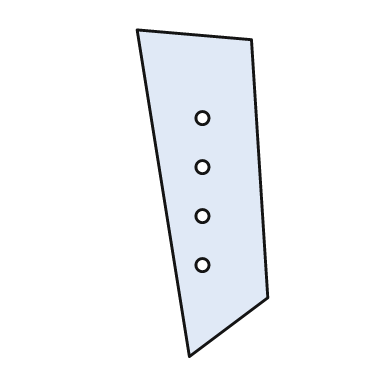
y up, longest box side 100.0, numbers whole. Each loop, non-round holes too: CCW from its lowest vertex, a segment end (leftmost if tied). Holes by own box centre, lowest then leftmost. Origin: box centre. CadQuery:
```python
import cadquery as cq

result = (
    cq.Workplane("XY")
    .moveTo(-4.0, -50.0)
    .lineTo(20.0, -32.0)
    .lineTo(15.0, 47.0)
    .lineTo(-20.0, 50.0)
    .close()
    .moveTo(0.0, -22.0)
    .circle(2.0)
    .moveTo(0.0, -7.0)
    .circle(2.0)
    .moveTo(0.0, 8.0)
    .circle(2.0)
    .moveTo(0.0, 23.0)
    .circle(2.0)
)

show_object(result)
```